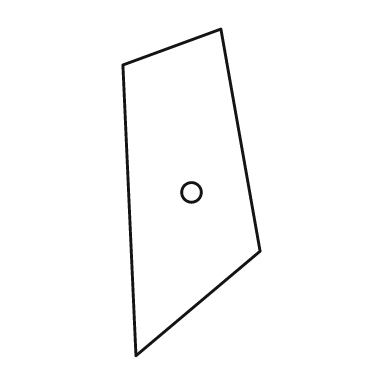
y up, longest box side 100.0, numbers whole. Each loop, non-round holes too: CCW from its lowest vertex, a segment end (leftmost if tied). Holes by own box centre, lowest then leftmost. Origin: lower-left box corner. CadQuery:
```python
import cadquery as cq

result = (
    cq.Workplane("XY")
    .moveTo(4.0, 0.0)
    .lineTo(42.0, 32.0)
    .lineTo(30.0, 100.0)
    .lineTo(0.0, 89.0)
    .close()
    .moveTo(21.0, 50.0)
    .circle(3.0)
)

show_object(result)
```